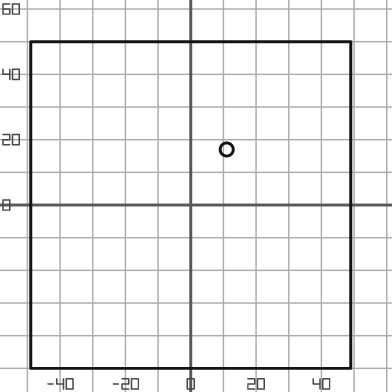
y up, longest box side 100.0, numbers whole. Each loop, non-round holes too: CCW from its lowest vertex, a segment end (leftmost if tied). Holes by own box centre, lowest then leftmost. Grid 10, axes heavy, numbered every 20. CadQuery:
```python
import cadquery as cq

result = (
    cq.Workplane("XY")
    .moveTo(-49.0, -50.0)
    .lineTo(49.0, -50.0)
    .lineTo(49.0, 50.0)
    .lineTo(-49.0, 50.0)
    .close()
    .moveTo(11.0, 17.0)
    .circle(2.0)
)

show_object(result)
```